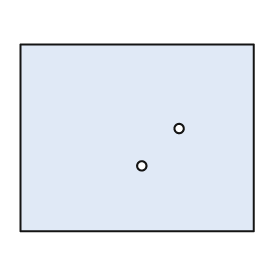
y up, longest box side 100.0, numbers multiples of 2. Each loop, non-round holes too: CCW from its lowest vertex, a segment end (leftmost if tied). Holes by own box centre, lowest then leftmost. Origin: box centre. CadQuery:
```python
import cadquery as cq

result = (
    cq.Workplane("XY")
    .moveTo(-50.0, -40.0)
    .lineTo(50.0, -40.0)
    .lineTo(50.0, 40.0)
    .lineTo(-50.0, 40.0)
    .close()
    .moveTo(2.0, -12.0)
    .circle(2.0)
    .moveTo(18.0, 4.0)
    .circle(2.0)
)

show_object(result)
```